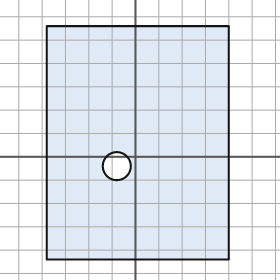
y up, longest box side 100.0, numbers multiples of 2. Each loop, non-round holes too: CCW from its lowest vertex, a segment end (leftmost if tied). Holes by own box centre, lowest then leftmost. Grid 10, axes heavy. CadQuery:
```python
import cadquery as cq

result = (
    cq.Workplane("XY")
    .moveTo(-38.0, -44.0)
    .lineTo(40.0, -44.0)
    .lineTo(40.0, 56.0)
    .lineTo(-38.0, 56.0)
    .close()
    .moveTo(-8.0, -4.0)
    .circle(6.0)
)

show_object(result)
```